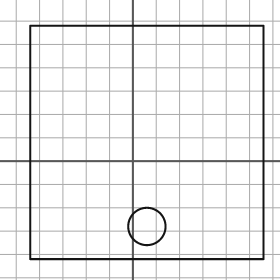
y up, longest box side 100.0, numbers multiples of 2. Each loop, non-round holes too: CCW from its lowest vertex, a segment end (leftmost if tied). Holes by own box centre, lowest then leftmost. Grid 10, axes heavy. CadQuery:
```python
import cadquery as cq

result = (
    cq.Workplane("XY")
    .moveTo(-44.0, -42.0)
    .lineTo(56.0, -42.0)
    .lineTo(56.0, 58.0)
    .lineTo(-44.0, 58.0)
    .close()
    .moveTo(6.0, -28.0)
    .circle(8.0)
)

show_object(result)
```